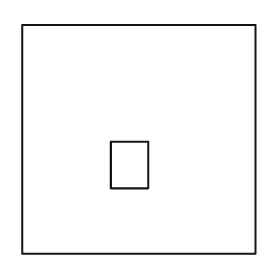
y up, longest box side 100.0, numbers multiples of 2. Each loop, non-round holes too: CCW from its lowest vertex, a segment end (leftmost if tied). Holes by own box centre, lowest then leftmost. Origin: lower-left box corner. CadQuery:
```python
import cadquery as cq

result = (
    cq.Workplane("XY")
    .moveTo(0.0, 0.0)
    .lineTo(100.0, 0.0)
    .lineTo(100.0, 98.0)
    .lineTo(0.0, 98.0)
    .close()
    .moveTo(38.0, 28.0)
    .lineTo(54.0, 28.0)
    .lineTo(54.0, 48.0)
    .lineTo(38.0, 48.0)
    .close()
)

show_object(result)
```